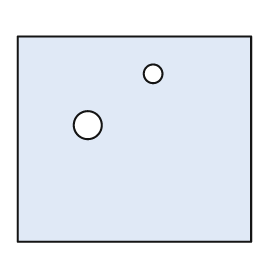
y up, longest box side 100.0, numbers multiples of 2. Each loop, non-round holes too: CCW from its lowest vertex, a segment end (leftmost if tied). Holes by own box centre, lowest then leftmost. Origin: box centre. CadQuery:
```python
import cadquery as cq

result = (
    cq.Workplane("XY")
    .moveTo(-50.0, -44.0)
    .lineTo(50.0, -44.0)
    .lineTo(50.0, 44.0)
    .lineTo(-50.0, 44.0)
    .close()
    .moveTo(-20.0, 6.0)
    .circle(6.0)
    .moveTo(8.0, 28.0)
    .circle(4.0)
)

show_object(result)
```